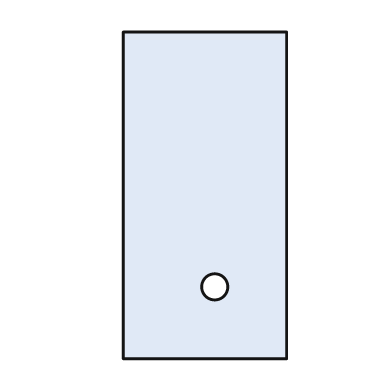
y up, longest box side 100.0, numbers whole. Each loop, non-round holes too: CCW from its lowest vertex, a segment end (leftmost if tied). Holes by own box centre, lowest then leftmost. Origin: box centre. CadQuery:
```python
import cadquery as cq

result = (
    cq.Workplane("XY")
    .moveTo(-25.0, -50.0)
    .lineTo(25.0, -50.0)
    .lineTo(25.0, 50.0)
    .lineTo(-25.0, 50.0)
    .close()
    .moveTo(3.0, -28.0)
    .circle(4.0)
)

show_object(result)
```